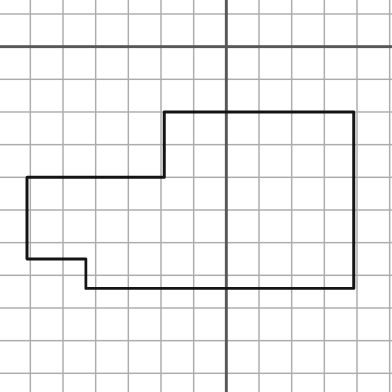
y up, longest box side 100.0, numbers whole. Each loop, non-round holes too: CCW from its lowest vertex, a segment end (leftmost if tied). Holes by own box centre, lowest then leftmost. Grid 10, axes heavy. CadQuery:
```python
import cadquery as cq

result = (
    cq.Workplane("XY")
    .moveTo(-43.0, -74.0)
    .lineTo(39.0, -74.0)
    .lineTo(39.0, -20.0)
    .lineTo(-19.0, -20.0)
    .lineTo(-19.0, -40.0)
    .lineTo(-61.0, -40.0)
    .lineTo(-61.0, -65.0)
    .lineTo(-43.0, -65.0)
    .close()
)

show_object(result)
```